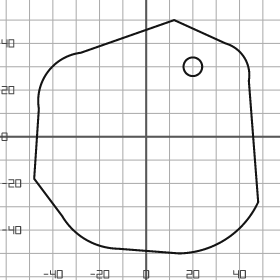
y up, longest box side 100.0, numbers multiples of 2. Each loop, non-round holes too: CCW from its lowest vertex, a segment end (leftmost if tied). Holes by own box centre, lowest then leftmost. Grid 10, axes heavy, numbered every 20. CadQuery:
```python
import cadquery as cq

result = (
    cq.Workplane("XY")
    .moveTo(14.0, -50.0)
    .threePointArc((34.0, -44.0), (48.0, -28.0))
    .lineTo(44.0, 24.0)
    .threePointArc((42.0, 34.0), (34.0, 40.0))
    .lineTo(12.0, 50.0)
    .lineTo(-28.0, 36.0)
    .threePointArc((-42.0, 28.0), (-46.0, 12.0))
    .lineTo(-48.0, -18.0)
    .lineTo(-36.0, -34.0)
    .threePointArc((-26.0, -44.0), (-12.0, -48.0))
    .close()
    .moveTo(20.0, 30.0)
    .circle(4.0)
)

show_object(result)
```